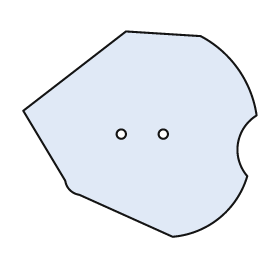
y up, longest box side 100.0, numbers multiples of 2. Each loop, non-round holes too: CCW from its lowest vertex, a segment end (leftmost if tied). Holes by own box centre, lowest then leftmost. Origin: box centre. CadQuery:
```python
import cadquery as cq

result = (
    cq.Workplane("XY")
    .moveTo(14.0, -44.0)
    .threePointArc((34.0, -36.0), (46.0, -18.0))
    .threePointArc((42.0, -4.0), (50.0, 8.0))
    .threePointArc((42.0, 28.0), (26.0, 42.0))
    .lineTo(-6.0, 44.0)
    .lineTo(-50.0, 10.0)
    .lineTo(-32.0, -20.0)
    .threePointArc((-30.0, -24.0), (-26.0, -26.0))
    .close()
    .moveTo(-8.0, 0.0)
    .circle(2.0)
    .moveTo(10.0, 0.0)
    .circle(2.0)
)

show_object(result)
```